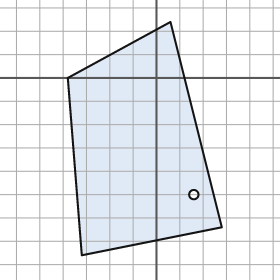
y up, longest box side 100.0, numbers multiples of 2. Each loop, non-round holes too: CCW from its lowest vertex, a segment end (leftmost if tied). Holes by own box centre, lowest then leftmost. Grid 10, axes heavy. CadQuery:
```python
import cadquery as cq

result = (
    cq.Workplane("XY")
    .moveTo(-32.0, -76.0)
    .lineTo(28.0, -64.0)
    .lineTo(6.0, 24.0)
    .lineTo(-38.0, 0.0)
    .close()
    .moveTo(16.0, -50.0)
    .circle(2.0)
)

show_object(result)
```